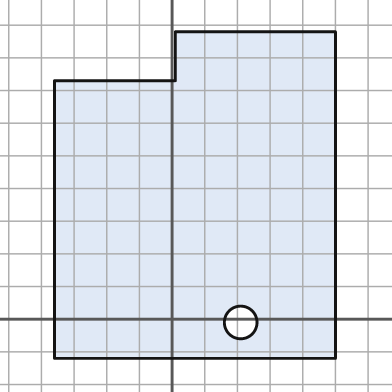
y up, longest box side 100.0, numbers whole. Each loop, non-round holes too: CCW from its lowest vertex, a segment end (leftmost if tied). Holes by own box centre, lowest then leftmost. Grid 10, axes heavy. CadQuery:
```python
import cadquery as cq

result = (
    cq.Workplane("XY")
    .moveTo(-36.0, -12.0)
    .lineTo(50.0, -12.0)
    .lineTo(50.0, 88.0)
    .lineTo(1.0, 88.0)
    .lineTo(1.0, 73.0)
    .lineTo(-36.0, 73.0)
    .close()
    .moveTo(21.0, -1.0)
    .circle(5.0)
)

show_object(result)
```